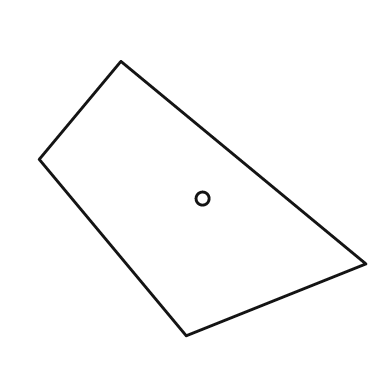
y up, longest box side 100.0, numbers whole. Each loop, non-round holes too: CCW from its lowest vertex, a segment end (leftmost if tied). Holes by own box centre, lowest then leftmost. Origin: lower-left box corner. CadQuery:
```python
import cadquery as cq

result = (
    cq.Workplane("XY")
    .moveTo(45.0, 0.0)
    .lineTo(100.0, 22.0)
    .lineTo(25.0, 84.0)
    .lineTo(0.0, 54.0)
    .close()
    .moveTo(50.0, 42.0)
    .circle(2.0)
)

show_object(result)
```